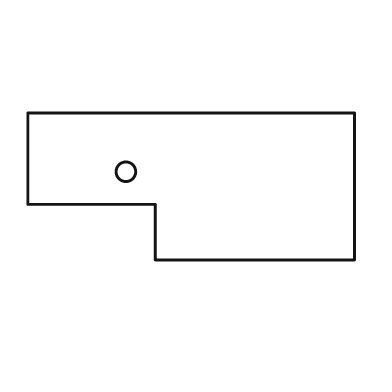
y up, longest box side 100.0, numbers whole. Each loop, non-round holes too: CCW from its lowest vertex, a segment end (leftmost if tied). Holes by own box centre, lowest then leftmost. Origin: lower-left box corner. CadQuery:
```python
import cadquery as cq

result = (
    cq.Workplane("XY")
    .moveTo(39.0, 0.0)
    .lineTo(100.0, 0.0)
    .lineTo(100.0, 45.0)
    .lineTo(0.0, 45.0)
    .lineTo(0.0, 17.0)
    .lineTo(39.0, 17.0)
    .close()
    .moveTo(30.0, 27.0)
    .circle(3.0)
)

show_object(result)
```